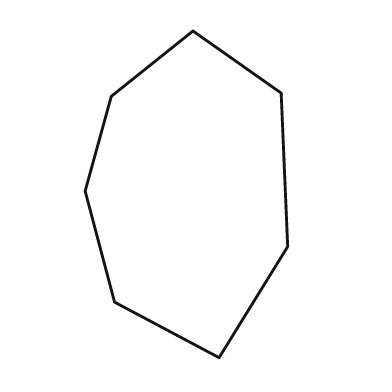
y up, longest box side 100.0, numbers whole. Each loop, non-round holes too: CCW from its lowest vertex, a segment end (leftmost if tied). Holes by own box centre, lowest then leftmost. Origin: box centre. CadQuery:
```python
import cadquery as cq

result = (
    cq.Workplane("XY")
    .moveTo(10.0, -50.0)
    .lineTo(31.0, -16.0)
    .lineTo(29.0, 31.0)
    .lineTo(2.0, 50.0)
    .lineTo(-23.0, 30.0)
    .lineTo(-31.0, 1.0)
    .lineTo(-22.0, -33.0)
    .close()
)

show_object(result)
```